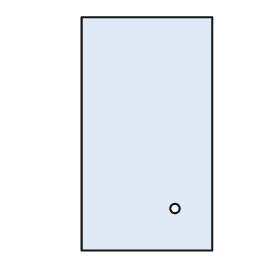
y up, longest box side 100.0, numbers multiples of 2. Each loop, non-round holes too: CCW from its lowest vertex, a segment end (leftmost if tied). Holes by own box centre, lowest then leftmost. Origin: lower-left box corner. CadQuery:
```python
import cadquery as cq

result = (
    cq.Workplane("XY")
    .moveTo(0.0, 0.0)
    .lineTo(56.0, 0.0)
    .lineTo(56.0, 100.0)
    .lineTo(0.0, 100.0)
    .close()
    .moveTo(40.0, 18.0)
    .circle(2.0)
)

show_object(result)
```